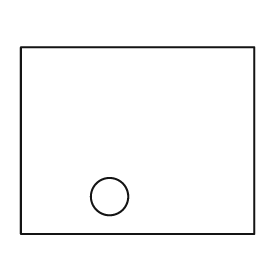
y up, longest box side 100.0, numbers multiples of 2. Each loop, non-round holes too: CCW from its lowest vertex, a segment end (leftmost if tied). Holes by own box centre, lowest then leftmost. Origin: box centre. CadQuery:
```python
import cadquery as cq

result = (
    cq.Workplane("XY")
    .moveTo(-50.0, -40.0)
    .lineTo(50.0, -40.0)
    .lineTo(50.0, 40.0)
    .lineTo(-50.0, 40.0)
    .close()
    .moveTo(-12.0, -24.0)
    .circle(8.0)
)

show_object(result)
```